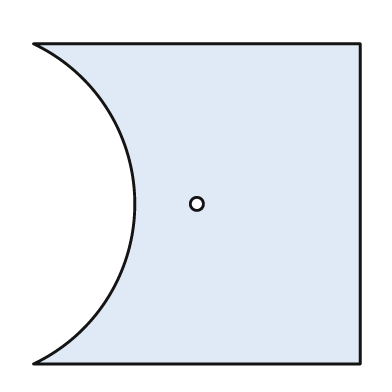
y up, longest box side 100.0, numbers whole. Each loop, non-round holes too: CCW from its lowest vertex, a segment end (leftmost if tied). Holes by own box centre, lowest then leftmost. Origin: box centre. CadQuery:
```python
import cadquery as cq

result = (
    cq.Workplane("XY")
    .moveTo(-50.0, -49.0)
    .lineTo(50.0, -49.0)
    .lineTo(50.0, 49.0)
    .lineTo(-50.0, 49.0)
    .threePointArc((-19.0, 0.0), (-50.0, -49.0))
    .close()
    .moveTo(0.0, 0.0)
    .circle(2.0)
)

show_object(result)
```